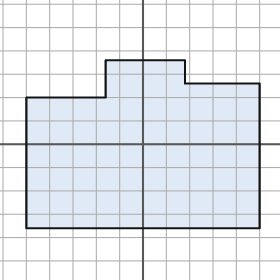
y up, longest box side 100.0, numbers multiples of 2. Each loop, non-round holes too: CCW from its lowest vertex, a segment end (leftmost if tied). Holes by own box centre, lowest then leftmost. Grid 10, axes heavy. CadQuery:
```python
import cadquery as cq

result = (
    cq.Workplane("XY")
    .moveTo(-50.0, -36.0)
    .lineTo(50.0, -36.0)
    .lineTo(50.0, 26.0)
    .lineTo(18.0, 26.0)
    .lineTo(18.0, 36.0)
    .lineTo(-16.0, 36.0)
    .lineTo(-16.0, 20.0)
    .lineTo(-50.0, 20.0)
    .close()
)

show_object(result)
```